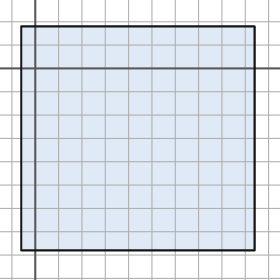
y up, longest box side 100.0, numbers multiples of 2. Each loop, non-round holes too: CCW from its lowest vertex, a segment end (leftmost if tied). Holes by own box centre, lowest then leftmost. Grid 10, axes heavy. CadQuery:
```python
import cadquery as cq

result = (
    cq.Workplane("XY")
    .moveTo(-6.0, -78.0)
    .lineTo(94.0, -78.0)
    .lineTo(94.0, 18.0)
    .lineTo(-6.0, 18.0)
    .close()
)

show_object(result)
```